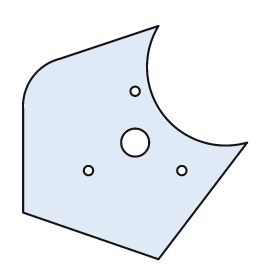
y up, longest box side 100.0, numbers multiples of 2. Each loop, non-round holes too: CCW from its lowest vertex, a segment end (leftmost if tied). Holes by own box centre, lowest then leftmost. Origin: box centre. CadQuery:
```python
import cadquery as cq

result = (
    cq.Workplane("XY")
    .moveTo(10.0, -50.0)
    .lineTo(48.0, 0.0)
    .threePointArc((12.0, 12.0), (10.0, 50.0))
    .lineTo(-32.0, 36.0)
    .threePointArc((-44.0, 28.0), (-48.0, 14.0))
    .lineTo(-48.0, -30.0)
    .close()
    .moveTo(-20.0, -12.0)
    .circle(2.0)
    .moveTo(20.0, -12.0)
    .circle(2.0)
    .moveTo(0.0, 0.0)
    .circle(6.0)
    .moveTo(0.0, 22.0)
    .circle(2.0)
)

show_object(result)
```